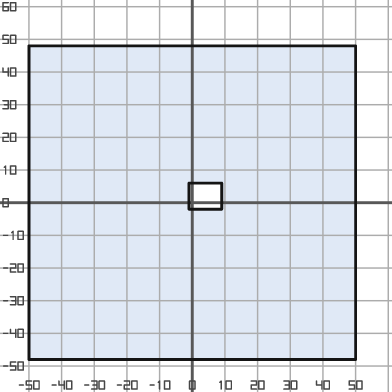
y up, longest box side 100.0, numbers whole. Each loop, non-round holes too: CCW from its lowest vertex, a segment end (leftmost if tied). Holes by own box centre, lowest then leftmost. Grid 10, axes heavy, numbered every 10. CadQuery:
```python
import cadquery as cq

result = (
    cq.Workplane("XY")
    .moveTo(-50.0, -48.0)
    .lineTo(50.0, -48.0)
    .lineTo(50.0, 48.0)
    .lineTo(-50.0, 48.0)
    .close()
    .moveTo(-1.0, -2.0)
    .lineTo(9.0, -2.0)
    .lineTo(9.0, 6.0)
    .lineTo(-1.0, 6.0)
    .close()
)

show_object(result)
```